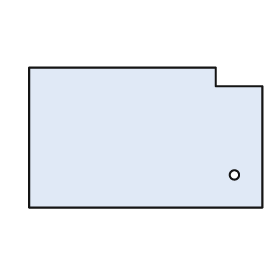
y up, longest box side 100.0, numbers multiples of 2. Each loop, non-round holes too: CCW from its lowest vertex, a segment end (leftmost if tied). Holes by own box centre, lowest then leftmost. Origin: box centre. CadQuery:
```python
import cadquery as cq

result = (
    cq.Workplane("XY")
    .moveTo(-50.0, -30.0)
    .lineTo(50.0, -30.0)
    .lineTo(50.0, 22.0)
    .lineTo(30.0, 22.0)
    .lineTo(30.0, 30.0)
    .lineTo(-50.0, 30.0)
    .close()
    .moveTo(38.0, -16.0)
    .circle(2.0)
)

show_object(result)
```